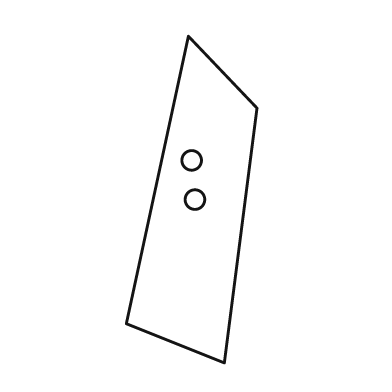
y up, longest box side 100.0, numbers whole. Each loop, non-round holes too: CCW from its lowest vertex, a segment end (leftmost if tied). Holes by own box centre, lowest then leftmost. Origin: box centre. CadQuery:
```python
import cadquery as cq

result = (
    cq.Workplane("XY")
    .moveTo(10.0, -50.0)
    .lineTo(20.0, 28.0)
    .lineTo(-1.0, 50.0)
    .lineTo(-20.0, -38.0)
    .close()
    .moveTo(1.0, 0.0)
    .circle(3.0)
    .moveTo(0.0, 12.0)
    .circle(3.0)
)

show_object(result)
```